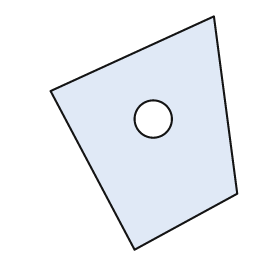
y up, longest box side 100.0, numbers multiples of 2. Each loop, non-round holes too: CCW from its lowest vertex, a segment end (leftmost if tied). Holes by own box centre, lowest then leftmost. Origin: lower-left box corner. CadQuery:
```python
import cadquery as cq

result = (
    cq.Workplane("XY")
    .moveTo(36.0, 0.0)
    .lineTo(80.0, 24.0)
    .lineTo(70.0, 100.0)
    .lineTo(0.0, 68.0)
    .close()
    .moveTo(44.0, 56.0)
    .circle(8.0)
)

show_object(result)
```